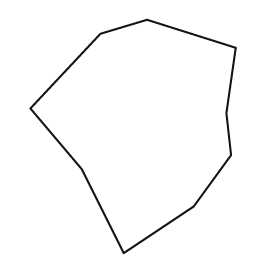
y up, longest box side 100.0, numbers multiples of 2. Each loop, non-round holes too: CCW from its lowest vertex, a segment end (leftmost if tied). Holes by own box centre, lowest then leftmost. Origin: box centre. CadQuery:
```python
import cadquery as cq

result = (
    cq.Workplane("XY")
    .moveTo(-4.0, -50.0)
    .lineTo(26.0, -30.0)
    .lineTo(42.0, -8.0)
    .lineTo(40.0, 10.0)
    .lineTo(44.0, 38.0)
    .lineTo(6.0, 50.0)
    .lineTo(-14.0, 44.0)
    .lineTo(-44.0, 12.0)
    .lineTo(-22.0, -14.0)
    .close()
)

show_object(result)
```